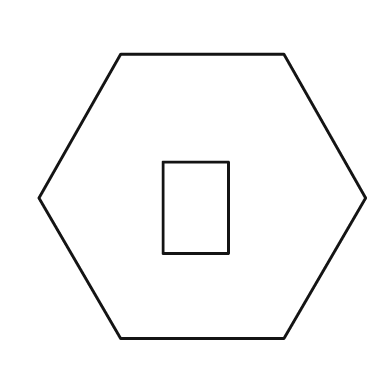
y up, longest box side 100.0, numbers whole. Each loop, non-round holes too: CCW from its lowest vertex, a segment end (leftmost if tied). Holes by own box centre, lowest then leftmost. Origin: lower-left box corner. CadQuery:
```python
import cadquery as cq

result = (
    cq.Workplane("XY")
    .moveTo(25.0, 0.0)
    .lineTo(75.0, 0.0)
    .lineTo(100.0, 43.0)
    .lineTo(75.0, 87.0)
    .lineTo(25.0, 87.0)
    .lineTo(0.0, 43.0)
    .close()
    .moveTo(38.0, 26.0)
    .lineTo(58.0, 26.0)
    .lineTo(58.0, 54.0)
    .lineTo(38.0, 54.0)
    .close()
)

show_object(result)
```